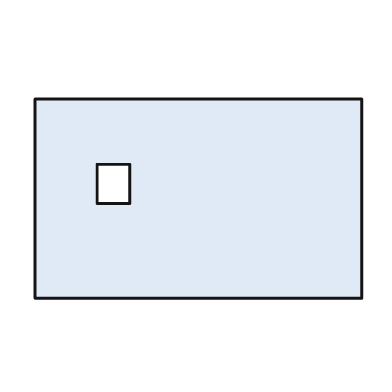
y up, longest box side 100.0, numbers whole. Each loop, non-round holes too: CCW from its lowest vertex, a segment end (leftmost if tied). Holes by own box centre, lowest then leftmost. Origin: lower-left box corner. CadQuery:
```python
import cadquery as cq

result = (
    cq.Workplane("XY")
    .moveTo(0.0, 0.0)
    .lineTo(100.0, 0.0)
    .lineTo(100.0, 61.0)
    .lineTo(0.0, 61.0)
    .close()
    .moveTo(19.0, 29.0)
    .lineTo(29.0, 29.0)
    .lineTo(29.0, 41.0)
    .lineTo(19.0, 41.0)
    .close()
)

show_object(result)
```